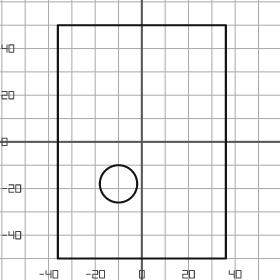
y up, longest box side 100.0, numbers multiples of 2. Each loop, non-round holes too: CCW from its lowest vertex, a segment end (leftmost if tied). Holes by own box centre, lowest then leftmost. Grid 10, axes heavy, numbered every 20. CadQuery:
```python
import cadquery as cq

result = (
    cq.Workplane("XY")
    .moveTo(-36.0, -50.0)
    .lineTo(36.0, -50.0)
    .lineTo(36.0, 50.0)
    .lineTo(-36.0, 50.0)
    .close()
    .moveTo(-10.0, -18.0)
    .circle(8.0)
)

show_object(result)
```